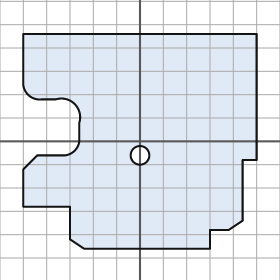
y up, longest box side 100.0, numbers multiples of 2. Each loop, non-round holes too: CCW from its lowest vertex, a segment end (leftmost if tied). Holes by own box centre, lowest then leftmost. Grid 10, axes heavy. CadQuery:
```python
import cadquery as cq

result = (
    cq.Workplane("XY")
    .moveTo(-24.0, -46.0)
    .lineTo(30.0, -46.0)
    .lineTo(30.0, -38.0)
    .lineTo(38.0, -38.0)
    .lineTo(44.0, -34.0)
    .lineTo(44.0, -8.0)
    .lineTo(50.0, -8.0)
    .lineTo(50.0, 46.0)
    .lineTo(-50.0, 46.0)
    .lineTo(-50.0, 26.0)
    .threePointArc((-48.0, 20.0), (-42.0, 18.0))
    .lineTo(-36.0, 18.0)
    .threePointArc((-28.0, 16.0), (-26.0, 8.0))
    .lineTo(-26.0, 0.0)
    .threePointArc((-28.0, -4.0), (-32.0, -6.0))
    .lineTo(-44.0, -6.0)
    .lineTo(-50.0, -12.0)
    .lineTo(-50.0, -28.0)
    .lineTo(-30.0, -28.0)
    .lineTo(-30.0, -42.0)
    .close()
    .moveTo(0.0, -6.0)
    .circle(4.0)
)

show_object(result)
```